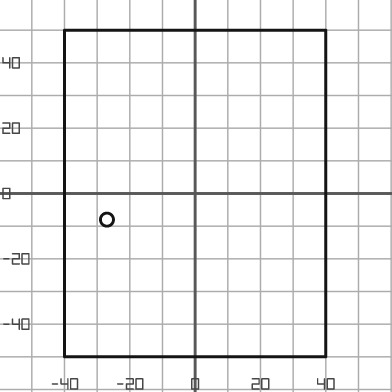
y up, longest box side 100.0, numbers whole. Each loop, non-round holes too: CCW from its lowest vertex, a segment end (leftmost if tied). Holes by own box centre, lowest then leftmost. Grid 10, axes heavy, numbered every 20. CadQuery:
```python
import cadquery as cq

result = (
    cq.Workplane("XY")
    .moveTo(-40.0, -50.0)
    .lineTo(40.0, -50.0)
    .lineTo(40.0, 50.0)
    .lineTo(-40.0, 50.0)
    .close()
    .moveTo(-27.0, -8.0)
    .circle(2.0)
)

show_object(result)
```